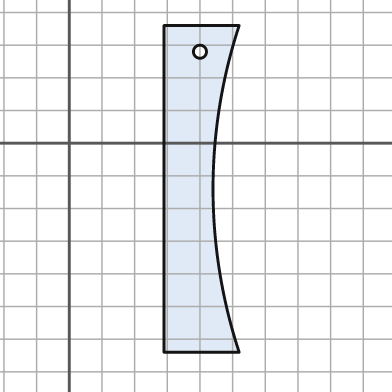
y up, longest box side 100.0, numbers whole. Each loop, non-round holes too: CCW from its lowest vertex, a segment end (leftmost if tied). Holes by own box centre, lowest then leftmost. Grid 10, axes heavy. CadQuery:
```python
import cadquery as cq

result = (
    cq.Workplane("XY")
    .moveTo(29.0, -64.0)
    .lineTo(52.0, -64.0)
    .threePointArc((44.0, -14.0), (52.0, 36.0))
    .lineTo(29.0, 36.0)
    .close()
    .moveTo(40.0, 28.0)
    .circle(2.0)
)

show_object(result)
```